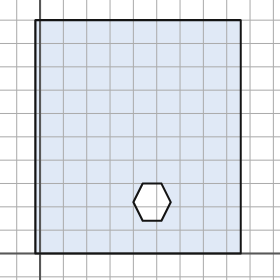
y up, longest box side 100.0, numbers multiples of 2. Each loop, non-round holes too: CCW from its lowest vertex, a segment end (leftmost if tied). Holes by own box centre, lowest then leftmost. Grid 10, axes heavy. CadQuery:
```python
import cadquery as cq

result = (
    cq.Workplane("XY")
    .moveTo(-2.0, 0.0)
    .lineTo(86.0, 0.0)
    .lineTo(86.0, 100.0)
    .lineTo(-2.0, 100.0)
    .close()
    .moveTo(44.0, 14.0)
    .lineTo(52.0, 14.0)
    .lineTo(56.0, 22.0)
    .lineTo(52.0, 30.0)
    .lineTo(44.0, 30.0)
    .lineTo(40.0, 22.0)
    .close()
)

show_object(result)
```